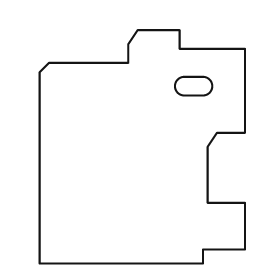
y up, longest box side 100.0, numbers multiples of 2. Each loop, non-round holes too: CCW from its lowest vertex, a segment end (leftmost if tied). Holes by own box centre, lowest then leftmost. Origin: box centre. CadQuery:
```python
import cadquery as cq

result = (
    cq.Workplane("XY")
    .moveTo(-44.0, -50.0)
    .lineTo(26.0, -50.0)
    .lineTo(26.0, -44.0)
    .lineTo(44.0, -44.0)
    .lineTo(44.0, -24.0)
    .lineTo(28.0, -24.0)
    .lineTo(28.0, 0.0)
    .lineTo(32.0, 6.0)
    .lineTo(44.0, 6.0)
    .lineTo(44.0, 42.0)
    .lineTo(16.0, 42.0)
    .lineTo(16.0, 50.0)
    .lineTo(-2.0, 50.0)
    .lineTo(-6.0, 44.0)
    .lineTo(-6.0, 36.0)
    .lineTo(-40.0, 36.0)
    .lineTo(-44.0, 32.0)
    .close()
    .moveTo(18.0, 22.0)
    .lineTo(26.0, 22.0)
    .threePointArc((30.0, 26.0), (26.0, 30.0))
    .lineTo(18.0, 30.0)
    .threePointArc((14.0, 26.0), (18.0, 22.0))
    .close()
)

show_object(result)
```